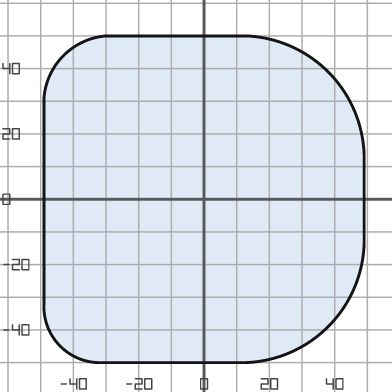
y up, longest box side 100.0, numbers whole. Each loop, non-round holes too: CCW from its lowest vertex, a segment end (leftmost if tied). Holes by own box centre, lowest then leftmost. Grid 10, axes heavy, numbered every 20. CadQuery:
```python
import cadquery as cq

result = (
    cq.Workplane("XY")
    .moveTo(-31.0, -50.0)
    .lineTo(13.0, -50.0)
    .threePointArc((38.0, -39.0), (49.0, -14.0))
    .lineTo(49.0, 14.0)
    .threePointArc((38.0, 39.0), (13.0, 50.0))
    .lineTo(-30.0, 50.0)
    .threePointArc((-43.0, 44.0), (-49.0, 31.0))
    .lineTo(-49.0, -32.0)
    .threePointArc((-44.0, -45.0), (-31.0, -50.0))
    .close()
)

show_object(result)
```